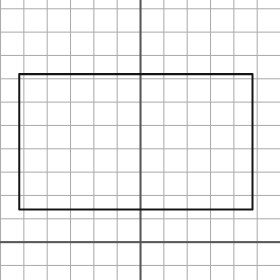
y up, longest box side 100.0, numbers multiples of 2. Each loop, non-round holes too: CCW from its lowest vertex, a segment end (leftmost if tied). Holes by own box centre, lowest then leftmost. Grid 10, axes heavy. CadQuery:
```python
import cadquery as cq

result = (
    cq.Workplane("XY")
    .moveTo(-52.0, 14.0)
    .lineTo(48.0, 14.0)
    .lineTo(48.0, 72.0)
    .lineTo(-52.0, 72.0)
    .close()
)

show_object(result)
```